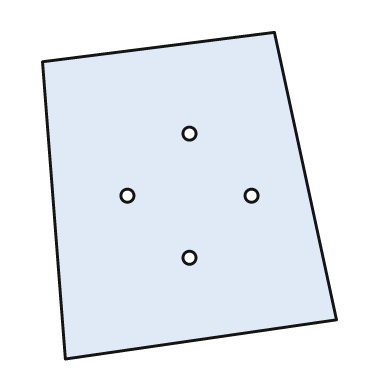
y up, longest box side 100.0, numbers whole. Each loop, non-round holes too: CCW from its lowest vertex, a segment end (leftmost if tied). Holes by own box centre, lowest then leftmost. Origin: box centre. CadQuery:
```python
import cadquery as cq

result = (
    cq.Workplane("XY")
    .moveTo(-38.0, -50.0)
    .lineTo(45.0, -38.0)
    .lineTo(26.0, 50.0)
    .lineTo(-45.0, 41.0)
    .close()
    .moveTo(0.0, -19.0)
    .circle(2.0)
    .moveTo(-19.0, 0.0)
    .circle(2.0)
    .moveTo(19.0, 0.0)
    .circle(2.0)
    .moveTo(0.0, 19.0)
    .circle(2.0)
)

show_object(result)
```